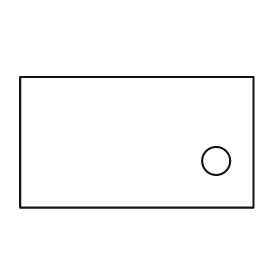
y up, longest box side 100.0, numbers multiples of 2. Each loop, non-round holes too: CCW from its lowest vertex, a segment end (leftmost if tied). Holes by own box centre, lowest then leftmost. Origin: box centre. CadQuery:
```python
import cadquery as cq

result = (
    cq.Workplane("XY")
    .moveTo(-50.0, -28.0)
    .lineTo(50.0, -28.0)
    .lineTo(50.0, 28.0)
    .lineTo(-50.0, 28.0)
    .close()
    .moveTo(34.0, -8.0)
    .circle(6.0)
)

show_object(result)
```